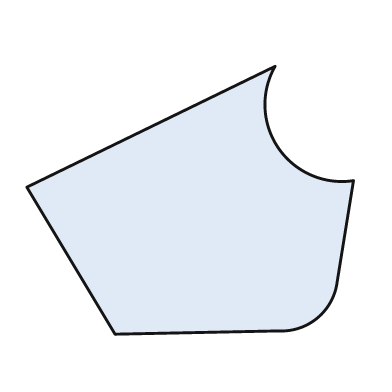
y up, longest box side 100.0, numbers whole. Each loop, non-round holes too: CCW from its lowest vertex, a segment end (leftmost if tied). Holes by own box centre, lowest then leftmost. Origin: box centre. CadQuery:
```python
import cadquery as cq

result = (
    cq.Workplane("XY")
    .moveTo(-23.0, -41.0)
    .lineTo(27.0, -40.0)
    .threePointArc((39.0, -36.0), (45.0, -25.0))
    .lineTo(50.0, 6.0)
    .threePointArc((27.0, 16.0), (26.0, 41.0))
    .lineTo(-50.0, 4.0)
    .close()
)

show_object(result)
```